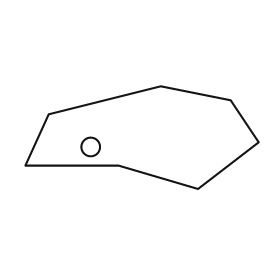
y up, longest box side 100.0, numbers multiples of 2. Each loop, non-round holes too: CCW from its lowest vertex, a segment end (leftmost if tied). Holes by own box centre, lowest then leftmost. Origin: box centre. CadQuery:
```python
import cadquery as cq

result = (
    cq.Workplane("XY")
    .moveTo(24.0, -22.0)
    .lineTo(50.0, -2.0)
    .lineTo(38.0, 16.0)
    .lineTo(8.0, 22.0)
    .lineTo(-40.0, 10.0)
    .lineTo(-50.0, -12.0)
    .lineTo(-10.0, -12.0)
    .close()
    .moveTo(-22.0, -4.0)
    .circle(4.0)
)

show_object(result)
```